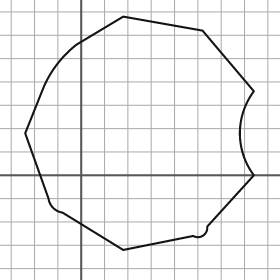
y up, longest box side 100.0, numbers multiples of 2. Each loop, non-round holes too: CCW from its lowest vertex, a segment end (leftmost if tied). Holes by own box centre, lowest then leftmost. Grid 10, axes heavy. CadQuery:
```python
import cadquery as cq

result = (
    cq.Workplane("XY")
    .moveTo(18.0, -32.0)
    .lineTo(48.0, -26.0)
    .threePointArc((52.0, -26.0), (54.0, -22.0))
    .lineTo(74.0, 0.0)
    .threePointArc((68.0, 18.0), (74.0, 36.0))
    .lineTo(52.0, 62.0)
    .lineTo(18.0, 68.0)
    .lineTo(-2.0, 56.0)
    .threePointArc((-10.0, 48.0), (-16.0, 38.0))
    .lineTo(-24.0, 18.0)
    .lineTo(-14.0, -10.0)
    .threePointArc((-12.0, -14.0), (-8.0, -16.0))
    .close()
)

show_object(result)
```